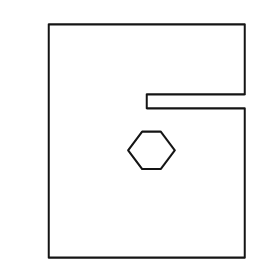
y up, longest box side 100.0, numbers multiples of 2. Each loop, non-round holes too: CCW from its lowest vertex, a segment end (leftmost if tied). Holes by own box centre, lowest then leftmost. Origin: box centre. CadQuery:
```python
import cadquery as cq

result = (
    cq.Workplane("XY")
    .moveTo(-42.0, -50.0)
    .lineTo(42.0, -50.0)
    .lineTo(42.0, 14.0)
    .lineTo(0.0, 14.0)
    .lineTo(0.0, 20.0)
    .lineTo(42.0, 20.0)
    .lineTo(42.0, 50.0)
    .lineTo(-42.0, 50.0)
    .close()
    .moveTo(-2.0, -12.0)
    .lineTo(6.0, -12.0)
    .lineTo(12.0, -4.0)
    .lineTo(6.0, 4.0)
    .lineTo(-2.0, 4.0)
    .lineTo(-8.0, -4.0)
    .close()
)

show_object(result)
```